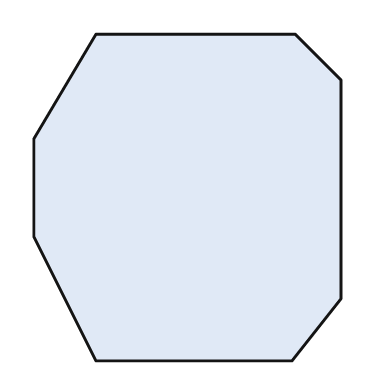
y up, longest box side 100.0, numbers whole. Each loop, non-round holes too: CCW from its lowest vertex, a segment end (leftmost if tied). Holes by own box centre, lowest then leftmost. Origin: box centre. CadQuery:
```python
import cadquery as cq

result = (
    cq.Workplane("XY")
    .moveTo(-28.0, -50.0)
    .lineTo(32.0, -50.0)
    .lineTo(47.0, -31.0)
    .lineTo(47.0, 36.0)
    .lineTo(33.0, 50.0)
    .lineTo(-28.0, 50.0)
    .lineTo(-47.0, 18.0)
    .lineTo(-47.0, -12.0)
    .close()
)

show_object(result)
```